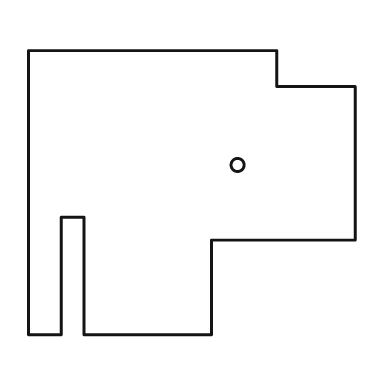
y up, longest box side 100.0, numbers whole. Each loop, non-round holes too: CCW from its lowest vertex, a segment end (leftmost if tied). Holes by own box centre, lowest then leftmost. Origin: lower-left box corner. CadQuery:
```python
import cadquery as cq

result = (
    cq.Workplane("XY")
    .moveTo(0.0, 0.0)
    .lineTo(10.0, 0.0)
    .lineTo(10.0, 36.0)
    .lineTo(17.0, 36.0)
    .lineTo(17.0, 0.0)
    .lineTo(56.0, 0.0)
    .lineTo(56.0, 29.0)
    .lineTo(100.0, 29.0)
    .lineTo(100.0, 76.0)
    .lineTo(76.0, 76.0)
    .lineTo(76.0, 87.0)
    .lineTo(0.0, 87.0)
    .close()
    .moveTo(64.0, 52.0)
    .circle(2.0)
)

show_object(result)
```